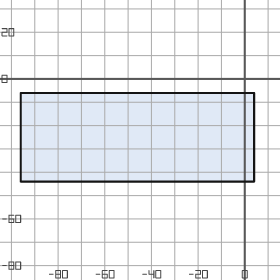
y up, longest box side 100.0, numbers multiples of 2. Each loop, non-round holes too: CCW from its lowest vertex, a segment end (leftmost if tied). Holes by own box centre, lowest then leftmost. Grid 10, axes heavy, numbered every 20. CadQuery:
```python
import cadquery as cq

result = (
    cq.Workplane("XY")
    .moveTo(-96.0, -44.0)
    .lineTo(4.0, -44.0)
    .lineTo(4.0, -6.0)
    .lineTo(-96.0, -6.0)
    .close()
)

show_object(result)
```